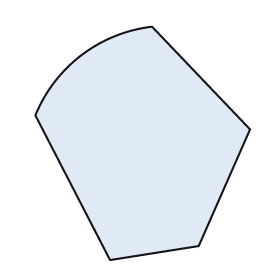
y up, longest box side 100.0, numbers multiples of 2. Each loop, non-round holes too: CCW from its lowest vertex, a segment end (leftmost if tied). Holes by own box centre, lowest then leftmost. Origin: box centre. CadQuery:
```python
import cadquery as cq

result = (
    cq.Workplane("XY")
    .moveTo(-14.0, -50.0)
    .lineTo(24.0, -44.0)
    .lineTo(46.0, 6.0)
    .lineTo(4.0, 50.0)
    .threePointArc((-26.0, 38.0), (-46.0, 12.0))
    .close()
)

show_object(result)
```